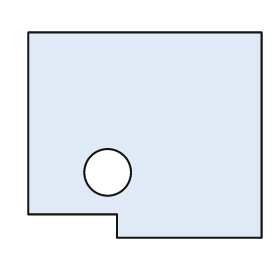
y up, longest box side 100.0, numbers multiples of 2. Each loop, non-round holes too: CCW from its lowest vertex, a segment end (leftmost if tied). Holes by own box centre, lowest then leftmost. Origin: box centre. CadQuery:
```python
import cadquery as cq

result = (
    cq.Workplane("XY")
    .moveTo(-12.0, -44.0)
    .lineTo(50.0, -44.0)
    .lineTo(50.0, 44.0)
    .lineTo(-50.0, 44.0)
    .lineTo(-50.0, -34.0)
    .lineTo(-12.0, -34.0)
    .close()
    .moveTo(-16.0, -16.0)
    .circle(10.0)
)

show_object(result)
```